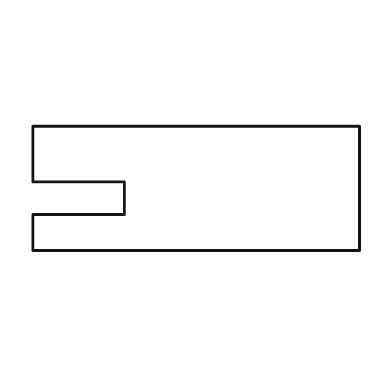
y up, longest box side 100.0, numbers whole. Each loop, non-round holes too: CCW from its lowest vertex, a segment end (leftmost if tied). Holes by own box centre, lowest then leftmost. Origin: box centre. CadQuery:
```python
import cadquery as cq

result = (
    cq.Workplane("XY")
    .moveTo(-50.0, -19.0)
    .lineTo(50.0, -19.0)
    .lineTo(50.0, 19.0)
    .lineTo(-50.0, 19.0)
    .lineTo(-50.0, 2.0)
    .lineTo(-22.0, 2.0)
    .lineTo(-22.0, -8.0)
    .lineTo(-50.0, -8.0)
    .close()
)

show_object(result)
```